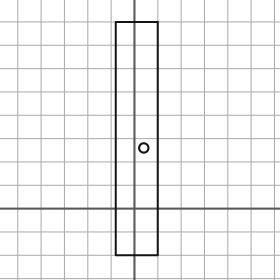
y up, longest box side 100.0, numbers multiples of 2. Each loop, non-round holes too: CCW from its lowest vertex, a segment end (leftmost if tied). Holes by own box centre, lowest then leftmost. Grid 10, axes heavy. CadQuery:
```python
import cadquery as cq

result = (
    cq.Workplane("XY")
    .moveTo(-8.0, -20.0)
    .lineTo(10.0, -20.0)
    .lineTo(10.0, 80.0)
    .lineTo(-8.0, 80.0)
    .close()
    .moveTo(4.0, 26.0)
    .circle(2.0)
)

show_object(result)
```